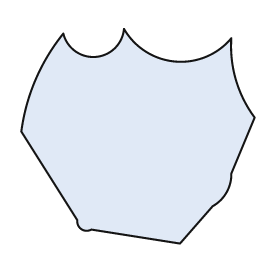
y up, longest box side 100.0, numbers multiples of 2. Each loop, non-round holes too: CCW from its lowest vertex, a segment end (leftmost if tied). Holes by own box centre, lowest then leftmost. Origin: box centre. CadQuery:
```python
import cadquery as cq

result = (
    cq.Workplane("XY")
    .moveTo(18.0, -46.0)
    .lineTo(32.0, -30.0)
    .threePointArc((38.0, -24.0), (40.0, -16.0))
    .lineTo(50.0, 8.0)
    .threePointArc((42.0, 24.0), (40.0, 42.0))
    .threePointArc((16.0, 32.0), (-6.0, 46.0))
    .threePointArc((-18.0, 34.0), (-32.0, 44.0))
    .threePointArc((-44.0, 24.0), (-50.0, 2.0))
    .lineTo(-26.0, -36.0)
    .threePointArc((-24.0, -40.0), (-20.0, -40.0))
    .close()
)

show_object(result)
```